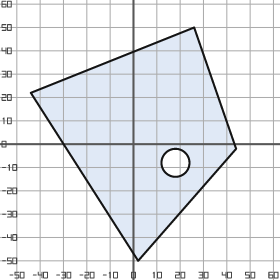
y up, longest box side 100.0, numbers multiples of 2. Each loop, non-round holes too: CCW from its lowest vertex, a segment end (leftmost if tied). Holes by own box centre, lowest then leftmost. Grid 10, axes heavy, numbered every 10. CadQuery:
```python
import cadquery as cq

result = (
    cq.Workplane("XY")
    .moveTo(2.0, -50.0)
    .lineTo(44.0, -2.0)
    .lineTo(26.0, 50.0)
    .lineTo(-44.0, 22.0)
    .close()
    .moveTo(18.0, -8.0)
    .circle(6.0)
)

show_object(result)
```